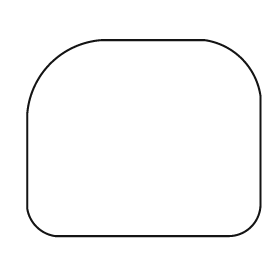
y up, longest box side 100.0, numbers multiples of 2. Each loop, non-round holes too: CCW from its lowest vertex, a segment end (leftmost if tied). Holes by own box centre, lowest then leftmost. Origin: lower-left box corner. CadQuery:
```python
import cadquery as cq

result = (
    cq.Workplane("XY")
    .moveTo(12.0, 0.0)
    .lineTo(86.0, 0.0)
    .threePointArc((96.0, 4.0), (100.0, 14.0))
    .lineTo(100.0, 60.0)
    .threePointArc((92.0, 76.0), (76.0, 84.0))
    .lineTo(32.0, 84.0)
    .threePointArc((10.0, 74.0), (0.0, 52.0))
    .lineTo(0.0, 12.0)
    .threePointArc((4.0, 4.0), (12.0, 0.0))
    .close()
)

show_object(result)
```